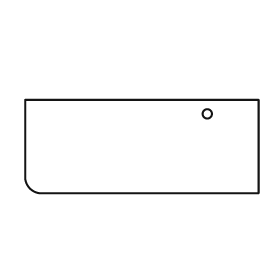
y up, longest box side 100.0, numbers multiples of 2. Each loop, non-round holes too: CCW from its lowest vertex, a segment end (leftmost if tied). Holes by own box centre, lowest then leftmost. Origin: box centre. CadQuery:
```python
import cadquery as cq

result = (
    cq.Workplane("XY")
    .moveTo(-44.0, -20.0)
    .lineTo(50.0, -20.0)
    .lineTo(50.0, 20.0)
    .lineTo(-50.0, 20.0)
    .lineTo(-50.0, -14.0)
    .threePointArc((-48.0, -18.0), (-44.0, -20.0))
    .close()
    .moveTo(28.0, 14.0)
    .circle(2.0)
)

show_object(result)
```